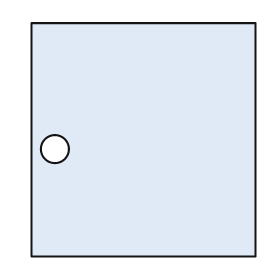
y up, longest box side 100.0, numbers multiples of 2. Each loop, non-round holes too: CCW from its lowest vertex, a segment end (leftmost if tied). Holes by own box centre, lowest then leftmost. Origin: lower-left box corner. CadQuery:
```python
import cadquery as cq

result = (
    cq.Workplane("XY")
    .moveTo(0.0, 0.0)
    .lineTo(96.0, 0.0)
    .lineTo(96.0, 100.0)
    .lineTo(0.0, 100.0)
    .close()
    .moveTo(10.0, 46.0)
    .circle(6.0)
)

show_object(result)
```